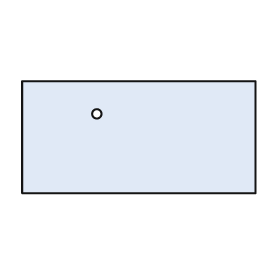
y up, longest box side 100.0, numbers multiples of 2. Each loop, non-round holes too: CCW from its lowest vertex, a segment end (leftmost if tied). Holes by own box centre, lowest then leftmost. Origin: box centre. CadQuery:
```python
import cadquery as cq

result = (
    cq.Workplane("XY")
    .moveTo(-50.0, -24.0)
    .lineTo(50.0, -24.0)
    .lineTo(50.0, 24.0)
    .lineTo(-50.0, 24.0)
    .close()
    .moveTo(-18.0, 10.0)
    .circle(2.0)
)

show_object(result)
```